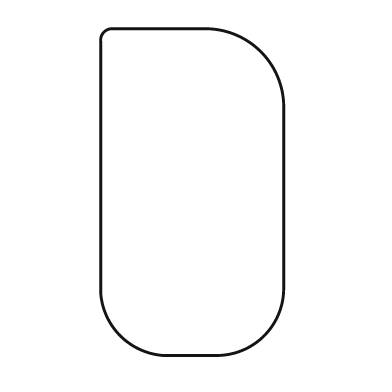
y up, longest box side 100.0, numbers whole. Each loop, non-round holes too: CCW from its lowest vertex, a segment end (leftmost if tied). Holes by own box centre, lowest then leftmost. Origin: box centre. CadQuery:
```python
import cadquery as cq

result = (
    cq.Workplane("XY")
    .moveTo(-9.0, -50.0)
    .lineTo(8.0, -50.0)
    .threePointArc((22.0, -44.0), (28.0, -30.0))
    .lineTo(28.0, 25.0)
    .threePointArc((21.0, 43.0), (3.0, 50.0))
    .lineTo(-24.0, 50.0)
    .threePointArc((-27.0, 49.0), (-28.0, 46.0))
    .lineTo(-28.0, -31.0)
    .threePointArc((-22.0, -44.0), (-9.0, -50.0))
    .close()
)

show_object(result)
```